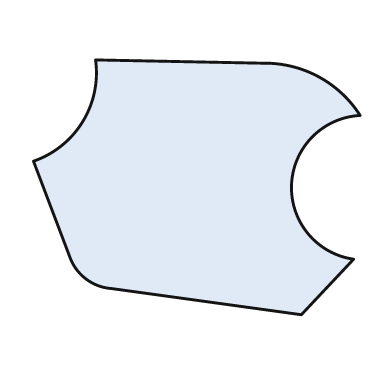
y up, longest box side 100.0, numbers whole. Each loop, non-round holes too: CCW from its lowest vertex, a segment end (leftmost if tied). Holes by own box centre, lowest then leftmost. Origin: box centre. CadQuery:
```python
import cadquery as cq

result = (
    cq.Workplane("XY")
    .moveTo(32.0, -39.0)
    .lineTo(48.0, -22.0)
    .threePointArc((29.0, 1.0), (50.0, 22.0))
    .threePointArc((37.0, 34.0), (20.0, 38.0))
    .lineTo(-31.0, 39.0)
    .threePointArc((-35.0, 20.0), (-50.0, 8.0))
    .lineTo(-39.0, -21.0)
    .threePointArc((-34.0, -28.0), (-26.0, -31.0))
    .close()
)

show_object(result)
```